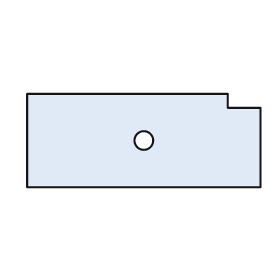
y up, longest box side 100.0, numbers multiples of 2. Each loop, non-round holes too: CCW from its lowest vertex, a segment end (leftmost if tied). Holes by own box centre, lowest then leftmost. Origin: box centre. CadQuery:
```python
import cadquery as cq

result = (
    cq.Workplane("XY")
    .moveTo(-50.0, -20.0)
    .lineTo(50.0, -20.0)
    .lineTo(50.0, 14.0)
    .lineTo(36.0, 14.0)
    .lineTo(36.0, 20.0)
    .lineTo(-50.0, 20.0)
    .close()
    .moveTo(0.0, 0.0)
    .circle(4.0)
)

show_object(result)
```